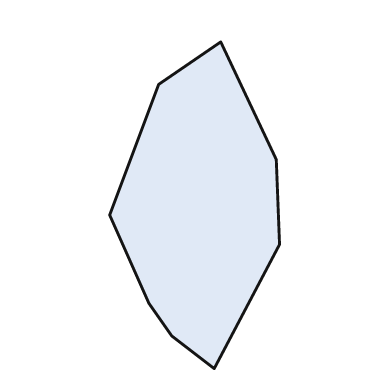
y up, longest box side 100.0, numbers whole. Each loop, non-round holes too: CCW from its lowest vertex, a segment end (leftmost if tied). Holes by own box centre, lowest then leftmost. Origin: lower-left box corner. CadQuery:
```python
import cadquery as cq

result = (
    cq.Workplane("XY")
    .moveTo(32.0, 0.0)
    .lineTo(52.0, 38.0)
    .lineTo(51.0, 64.0)
    .lineTo(34.0, 100.0)
    .lineTo(15.0, 87.0)
    .lineTo(0.0, 47.0)
    .lineTo(12.0, 20.0)
    .lineTo(19.0, 10.0)
    .close()
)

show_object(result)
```